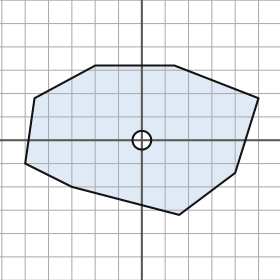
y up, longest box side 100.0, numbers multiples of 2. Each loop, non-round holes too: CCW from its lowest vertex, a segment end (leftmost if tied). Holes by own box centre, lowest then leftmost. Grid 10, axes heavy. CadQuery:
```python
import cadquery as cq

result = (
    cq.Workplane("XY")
    .moveTo(16.0, -32.0)
    .lineTo(40.0, -14.0)
    .lineTo(50.0, 18.0)
    .lineTo(14.0, 32.0)
    .lineTo(-20.0, 32.0)
    .lineTo(-46.0, 18.0)
    .lineTo(-50.0, -10.0)
    .lineTo(-30.0, -20.0)
    .close()
    .moveTo(0.0, 0.0)
    .circle(4.0)
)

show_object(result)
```